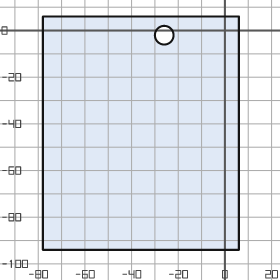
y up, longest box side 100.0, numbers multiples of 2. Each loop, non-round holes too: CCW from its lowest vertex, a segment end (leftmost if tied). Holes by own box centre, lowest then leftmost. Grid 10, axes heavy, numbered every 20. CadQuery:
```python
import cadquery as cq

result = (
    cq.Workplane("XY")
    .moveTo(-78.0, -94.0)
    .lineTo(6.0, -94.0)
    .lineTo(6.0, 6.0)
    .lineTo(-78.0, 6.0)
    .close()
    .moveTo(-26.0, -2.0)
    .circle(4.0)
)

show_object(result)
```